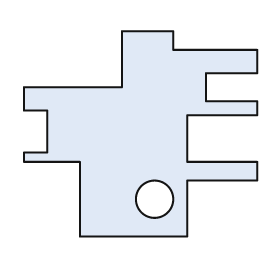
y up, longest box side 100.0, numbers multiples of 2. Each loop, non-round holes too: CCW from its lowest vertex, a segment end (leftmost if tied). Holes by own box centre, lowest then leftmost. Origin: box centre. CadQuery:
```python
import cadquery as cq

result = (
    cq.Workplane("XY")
    .moveTo(-26.0, -44.0)
    .lineTo(20.0, -44.0)
    .lineTo(20.0, -20.0)
    .lineTo(50.0, -20.0)
    .lineTo(50.0, -12.0)
    .lineTo(20.0, -12.0)
    .lineTo(20.0, 8.0)
    .lineTo(50.0, 8.0)
    .lineTo(50.0, 14.0)
    .lineTo(28.0, 14.0)
    .lineTo(28.0, 26.0)
    .lineTo(50.0, 26.0)
    .lineTo(50.0, 36.0)
    .lineTo(14.0, 36.0)
    .lineTo(14.0, 44.0)
    .lineTo(-8.0, 44.0)
    .lineTo(-8.0, 20.0)
    .lineTo(-50.0, 20.0)
    .lineTo(-50.0, 10.0)
    .lineTo(-40.0, 10.0)
    .lineTo(-40.0, -8.0)
    .lineTo(-50.0, -8.0)
    .lineTo(-50.0, -12.0)
    .lineTo(-26.0, -12.0)
    .close()
    .moveTo(6.0, -28.0)
    .circle(8.0)
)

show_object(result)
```